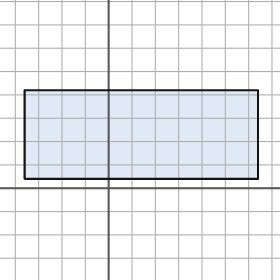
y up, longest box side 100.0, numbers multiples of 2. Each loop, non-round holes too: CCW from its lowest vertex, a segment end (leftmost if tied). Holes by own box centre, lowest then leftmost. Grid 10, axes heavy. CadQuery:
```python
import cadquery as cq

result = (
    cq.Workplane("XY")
    .moveTo(-36.0, 4.0)
    .lineTo(64.0, 4.0)
    .lineTo(64.0, 42.0)
    .lineTo(-36.0, 42.0)
    .close()
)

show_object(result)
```